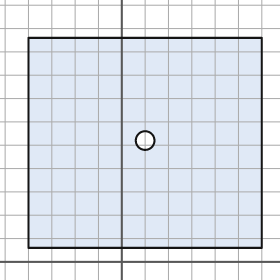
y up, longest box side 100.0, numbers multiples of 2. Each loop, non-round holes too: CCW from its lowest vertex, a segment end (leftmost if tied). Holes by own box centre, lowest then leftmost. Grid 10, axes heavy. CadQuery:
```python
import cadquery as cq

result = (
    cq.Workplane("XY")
    .moveTo(-40.0, 6.0)
    .lineTo(60.0, 6.0)
    .lineTo(60.0, 96.0)
    .lineTo(-40.0, 96.0)
    .close()
    .moveTo(10.0, 52.0)
    .circle(4.0)
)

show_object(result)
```